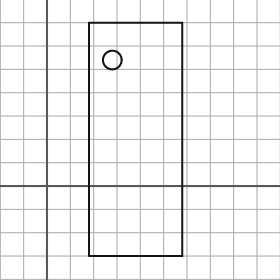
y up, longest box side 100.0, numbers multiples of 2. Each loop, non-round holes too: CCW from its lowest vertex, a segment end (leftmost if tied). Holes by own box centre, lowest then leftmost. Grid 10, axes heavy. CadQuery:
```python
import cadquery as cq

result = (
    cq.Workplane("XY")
    .moveTo(18.0, -30.0)
    .lineTo(58.0, -30.0)
    .lineTo(58.0, 70.0)
    .lineTo(18.0, 70.0)
    .close()
    .moveTo(28.0, 54.0)
    .circle(4.0)
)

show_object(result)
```